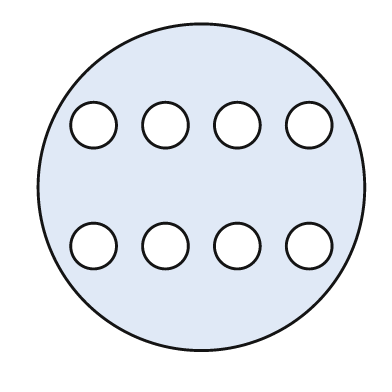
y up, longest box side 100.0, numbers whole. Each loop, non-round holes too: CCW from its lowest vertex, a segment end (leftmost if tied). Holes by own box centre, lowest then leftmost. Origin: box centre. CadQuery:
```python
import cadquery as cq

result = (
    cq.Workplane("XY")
    .moveTo(0.0, 0.0)
    .circle(50.0)
    .moveTo(-33.0, -18.0)
    .circle(7.0)
    .moveTo(-11.0, -18.0)
    .circle(7.0)
    .moveTo(11.0, -18.0)
    .circle(7.0)
    .moveTo(33.0, -18.0)
    .circle(7.0)
    .moveTo(-33.0, 19.0)
    .circle(7.0)
    .moveTo(-11.0, 19.0)
    .circle(7.0)
    .moveTo(11.0, 19.0)
    .circle(7.0)
    .moveTo(33.0, 19.0)
    .circle(7.0)
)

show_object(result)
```